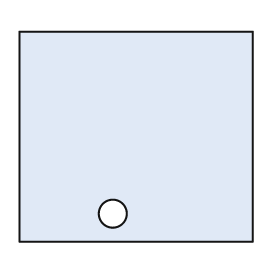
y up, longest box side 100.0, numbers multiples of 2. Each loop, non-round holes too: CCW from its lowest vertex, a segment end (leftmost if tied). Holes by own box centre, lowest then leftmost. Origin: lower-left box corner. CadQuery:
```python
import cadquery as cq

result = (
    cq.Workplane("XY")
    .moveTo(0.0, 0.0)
    .lineTo(100.0, 0.0)
    .lineTo(100.0, 90.0)
    .lineTo(0.0, 90.0)
    .close()
    .moveTo(40.0, 12.0)
    .circle(6.0)
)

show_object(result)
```